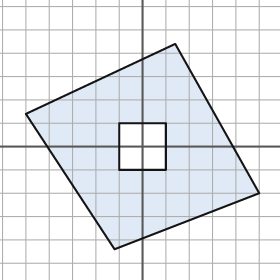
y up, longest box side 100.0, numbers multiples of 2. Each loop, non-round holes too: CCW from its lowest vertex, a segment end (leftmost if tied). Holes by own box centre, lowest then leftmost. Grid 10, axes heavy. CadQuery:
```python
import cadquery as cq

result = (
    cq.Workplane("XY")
    .moveTo(-12.0, -44.0)
    .lineTo(50.0, -20.0)
    .lineTo(14.0, 44.0)
    .lineTo(-50.0, 14.0)
    .close()
    .moveTo(-10.0, -10.0)
    .lineTo(10.0, -10.0)
    .lineTo(10.0, 10.0)
    .lineTo(-10.0, 10.0)
    .close()
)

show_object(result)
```